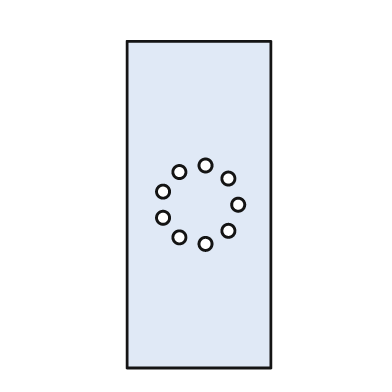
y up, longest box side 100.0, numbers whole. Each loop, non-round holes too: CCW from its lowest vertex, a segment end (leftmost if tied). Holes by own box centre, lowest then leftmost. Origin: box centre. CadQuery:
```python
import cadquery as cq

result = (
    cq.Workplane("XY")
    .moveTo(-22.0, -50.0)
    .lineTo(22.0, -50.0)
    .lineTo(22.0, 50.0)
    .lineTo(-22.0, 50.0)
    .close()
    .moveTo(2.0, -12.0)
    .circle(2.0)
    .moveTo(-6.0, -10.0)
    .circle(2.0)
    .moveTo(9.0, -8.0)
    .circle(2.0)
    .moveTo(-11.0, -4.0)
    .circle(2.0)
    .moveTo(12.0, 0.0)
    .circle(2.0)
    .moveTo(-11.0, 4.0)
    .circle(2.0)
    .moveTo(9.0, 8.0)
    .circle(2.0)
    .moveTo(-6.0, 10.0)
    .circle(2.0)
    .moveTo(2.0, 12.0)
    .circle(2.0)
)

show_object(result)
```